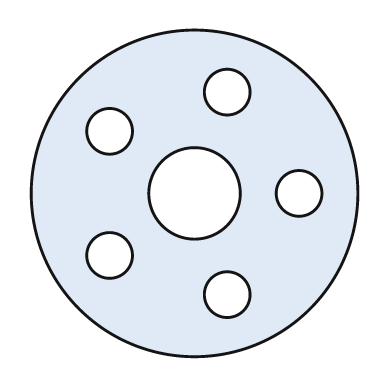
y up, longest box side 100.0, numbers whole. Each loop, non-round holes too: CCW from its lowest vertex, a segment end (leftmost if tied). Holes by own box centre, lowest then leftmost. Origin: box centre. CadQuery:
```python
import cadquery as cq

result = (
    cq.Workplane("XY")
    .moveTo(0.0, 0.0)
    .circle(50.0)
    .moveTo(10.0, -31.0)
    .circle(7.0)
    .moveTo(-26.0, -19.0)
    .circle(7.0)
    .moveTo(0.0, 0.0)
    .circle(14.0)
    .moveTo(32.0, 0.0)
    .circle(7.0)
    .moveTo(-26.0, 19.0)
    .circle(7.0)
    .moveTo(10.0, 31.0)
    .circle(7.0)
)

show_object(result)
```